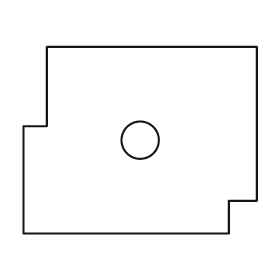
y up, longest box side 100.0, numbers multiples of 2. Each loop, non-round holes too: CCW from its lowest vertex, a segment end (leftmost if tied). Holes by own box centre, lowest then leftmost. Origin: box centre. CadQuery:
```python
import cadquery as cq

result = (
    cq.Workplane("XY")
    .moveTo(-50.0, -40.0)
    .lineTo(38.0, -40.0)
    .lineTo(38.0, -26.0)
    .lineTo(50.0, -26.0)
    .lineTo(50.0, 40.0)
    .lineTo(-40.0, 40.0)
    .lineTo(-40.0, 6.0)
    .lineTo(-50.0, 6.0)
    .close()
    .moveTo(0.0, 0.0)
    .circle(8.0)
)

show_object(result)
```